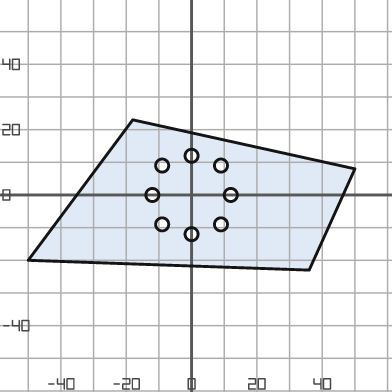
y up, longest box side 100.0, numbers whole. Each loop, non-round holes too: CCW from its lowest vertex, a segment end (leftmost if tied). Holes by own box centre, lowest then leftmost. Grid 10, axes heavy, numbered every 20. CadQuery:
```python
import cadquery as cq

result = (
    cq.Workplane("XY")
    .moveTo(36.0, -23.0)
    .lineTo(50.0, 8.0)
    .lineTo(-18.0, 23.0)
    .lineTo(-50.0, -20.0)
    .close()
    .moveTo(0.0, -12.0)
    .circle(2.0)
    .moveTo(-9.0, -9.0)
    .circle(2.0)
    .moveTo(9.0, -9.0)
    .circle(2.0)
    .moveTo(-12.0, 0.0)
    .circle(2.0)
    .moveTo(12.0, 0.0)
    .circle(2.0)
    .moveTo(-9.0, 9.0)
    .circle(2.0)
    .moveTo(9.0, 9.0)
    .circle(2.0)
    .moveTo(0.0, 12.0)
    .circle(2.0)
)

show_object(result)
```